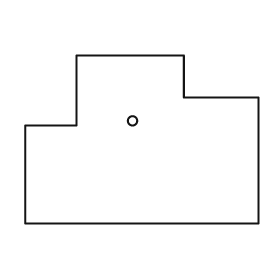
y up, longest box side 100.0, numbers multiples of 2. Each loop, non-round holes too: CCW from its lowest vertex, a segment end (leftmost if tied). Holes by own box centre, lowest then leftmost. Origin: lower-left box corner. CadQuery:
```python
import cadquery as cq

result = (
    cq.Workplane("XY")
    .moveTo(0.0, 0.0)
    .lineTo(100.0, 0.0)
    .lineTo(100.0, 54.0)
    .lineTo(68.0, 54.0)
    .lineTo(68.0, 72.0)
    .lineTo(22.0, 72.0)
    .lineTo(22.0, 42.0)
    .lineTo(0.0, 42.0)
    .close()
    .moveTo(46.0, 44.0)
    .circle(2.0)
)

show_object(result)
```